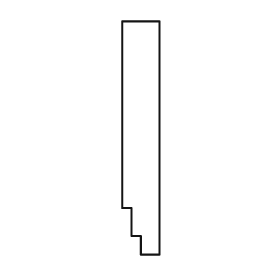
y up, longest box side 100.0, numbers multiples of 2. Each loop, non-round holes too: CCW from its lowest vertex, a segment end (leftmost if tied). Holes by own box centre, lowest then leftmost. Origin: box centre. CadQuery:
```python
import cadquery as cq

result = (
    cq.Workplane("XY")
    .moveTo(0.0, -50.0)
    .lineTo(8.0, -50.0)
    .lineTo(8.0, 50.0)
    .lineTo(-8.0, 50.0)
    .lineTo(-8.0, -30.0)
    .lineTo(-4.0, -30.0)
    .lineTo(-4.0, -42.0)
    .lineTo(0.0, -42.0)
    .close()
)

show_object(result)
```